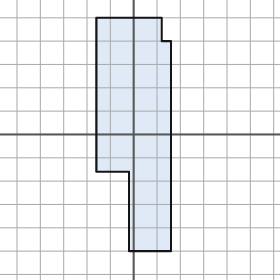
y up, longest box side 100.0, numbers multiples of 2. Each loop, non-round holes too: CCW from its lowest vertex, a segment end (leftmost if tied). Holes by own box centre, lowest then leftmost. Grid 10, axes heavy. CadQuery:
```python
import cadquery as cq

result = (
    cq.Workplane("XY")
    .moveTo(-2.0, -50.0)
    .lineTo(16.0, -50.0)
    .lineTo(16.0, 40.0)
    .lineTo(12.0, 40.0)
    .lineTo(12.0, 50.0)
    .lineTo(-16.0, 50.0)
    .lineTo(-16.0, -16.0)
    .lineTo(-2.0, -16.0)
    .close()
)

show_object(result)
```